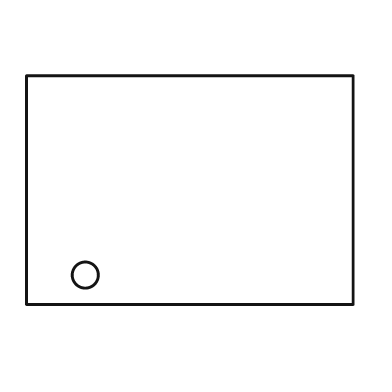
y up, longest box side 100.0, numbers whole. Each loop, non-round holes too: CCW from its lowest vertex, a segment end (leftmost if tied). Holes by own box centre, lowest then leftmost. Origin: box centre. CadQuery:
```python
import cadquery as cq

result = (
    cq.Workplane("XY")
    .moveTo(-50.0, -35.0)
    .lineTo(50.0, -35.0)
    .lineTo(50.0, 35.0)
    .lineTo(-50.0, 35.0)
    .close()
    .moveTo(-32.0, -26.0)
    .circle(4.0)
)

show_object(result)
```